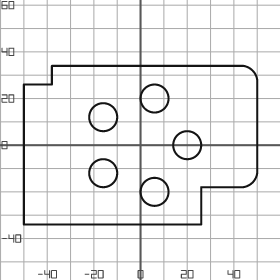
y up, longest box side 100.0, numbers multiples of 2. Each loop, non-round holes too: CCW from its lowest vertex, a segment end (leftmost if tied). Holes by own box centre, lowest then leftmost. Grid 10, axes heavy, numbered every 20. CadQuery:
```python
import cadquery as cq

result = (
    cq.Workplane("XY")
    .moveTo(-50.0, -34.0)
    .lineTo(26.0, -34.0)
    .lineTo(26.0, -18.0)
    .lineTo(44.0, -18.0)
    .threePointArc((48.0, -16.0), (50.0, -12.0))
    .lineTo(50.0, 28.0)
    .threePointArc((48.0, 32.0), (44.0, 34.0))
    .lineTo(-38.0, 34.0)
    .lineTo(-38.0, 26.0)
    .lineTo(-50.0, 26.0)
    .close()
    .moveTo(6.0, -20.0)
    .circle(6.0)
    .moveTo(-16.0, -12.0)
    .circle(6.0)
    .moveTo(20.0, 0.0)
    .circle(6.0)
    .moveTo(-16.0, 12.0)
    .circle(6.0)
    .moveTo(6.0, 20.0)
    .circle(6.0)
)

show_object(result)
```